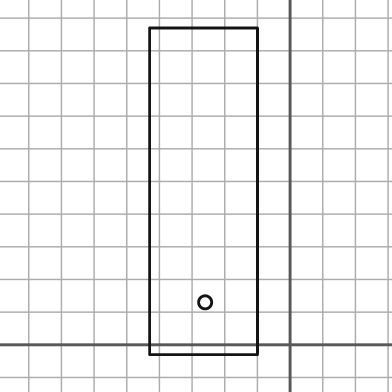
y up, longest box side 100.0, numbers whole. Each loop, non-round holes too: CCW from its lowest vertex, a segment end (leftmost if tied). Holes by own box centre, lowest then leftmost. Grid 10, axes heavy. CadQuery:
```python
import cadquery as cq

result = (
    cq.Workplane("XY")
    .moveTo(-43.0, -3.0)
    .lineTo(-10.0, -3.0)
    .lineTo(-10.0, 97.0)
    .lineTo(-43.0, 97.0)
    .close()
    .moveTo(-26.0, 13.0)
    .circle(2.0)
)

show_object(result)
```